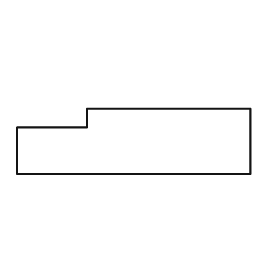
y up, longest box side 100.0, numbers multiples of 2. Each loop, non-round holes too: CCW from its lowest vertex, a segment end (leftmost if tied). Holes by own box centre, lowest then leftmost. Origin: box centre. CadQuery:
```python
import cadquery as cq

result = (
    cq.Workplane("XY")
    .moveTo(-50.0, -14.0)
    .lineTo(50.0, -14.0)
    .lineTo(50.0, 14.0)
    .lineTo(-20.0, 14.0)
    .lineTo(-20.0, 6.0)
    .lineTo(-50.0, 6.0)
    .close()
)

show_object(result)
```